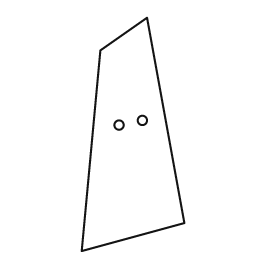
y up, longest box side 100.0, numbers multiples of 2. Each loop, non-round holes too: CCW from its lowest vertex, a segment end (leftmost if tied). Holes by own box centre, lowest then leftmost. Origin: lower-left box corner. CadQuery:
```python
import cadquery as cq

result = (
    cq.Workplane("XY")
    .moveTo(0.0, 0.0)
    .lineTo(44.0, 12.0)
    .lineTo(28.0, 100.0)
    .lineTo(8.0, 86.0)
    .close()
    .moveTo(16.0, 54.0)
    .circle(2.0)
    .moveTo(26.0, 56.0)
    .circle(2.0)
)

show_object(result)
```